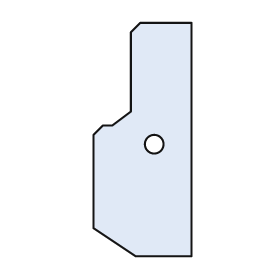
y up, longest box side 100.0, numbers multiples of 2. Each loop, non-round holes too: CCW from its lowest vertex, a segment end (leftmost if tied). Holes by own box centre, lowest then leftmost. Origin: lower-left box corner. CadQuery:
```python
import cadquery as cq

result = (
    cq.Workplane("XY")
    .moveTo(18.0, 0.0)
    .lineTo(42.0, 0.0)
    .lineTo(42.0, 100.0)
    .lineTo(20.0, 100.0)
    .lineTo(16.0, 96.0)
    .lineTo(16.0, 62.0)
    .lineTo(8.0, 56.0)
    .lineTo(4.0, 56.0)
    .lineTo(0.0, 52.0)
    .lineTo(0.0, 12.0)
    .close()
    .moveTo(26.0, 48.0)
    .circle(4.0)
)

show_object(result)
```